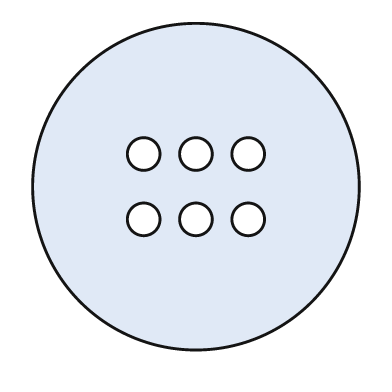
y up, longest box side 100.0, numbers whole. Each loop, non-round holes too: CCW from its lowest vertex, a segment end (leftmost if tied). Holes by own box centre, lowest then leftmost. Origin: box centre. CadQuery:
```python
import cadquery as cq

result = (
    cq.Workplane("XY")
    .moveTo(0.0, 0.0)
    .circle(50.0)
    .moveTo(-16.0, -10.0)
    .circle(5.0)
    .moveTo(0.0, -10.0)
    .circle(5.0)
    .moveTo(16.0, -10.0)
    .circle(5.0)
    .moveTo(-16.0, 10.0)
    .circle(5.0)
    .moveTo(0.0, 10.0)
    .circle(5.0)
    .moveTo(16.0, 10.0)
    .circle(5.0)
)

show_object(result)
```